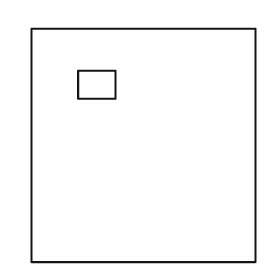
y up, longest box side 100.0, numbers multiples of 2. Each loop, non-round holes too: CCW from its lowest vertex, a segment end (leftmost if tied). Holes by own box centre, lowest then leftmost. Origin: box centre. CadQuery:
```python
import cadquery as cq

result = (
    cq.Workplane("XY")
    .moveTo(-48.0, -50.0)
    .lineTo(48.0, -50.0)
    .lineTo(48.0, 50.0)
    .lineTo(-48.0, 50.0)
    .close()
    .moveTo(-28.0, 20.0)
    .lineTo(-12.0, 20.0)
    .lineTo(-12.0, 32.0)
    .lineTo(-28.0, 32.0)
    .close()
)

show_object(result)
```